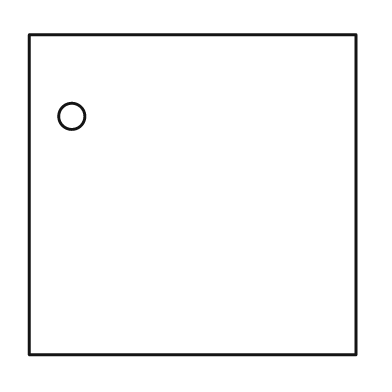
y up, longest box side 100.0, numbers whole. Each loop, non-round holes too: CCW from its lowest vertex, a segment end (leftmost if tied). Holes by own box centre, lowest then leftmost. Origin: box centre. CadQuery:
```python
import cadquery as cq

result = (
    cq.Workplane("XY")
    .moveTo(-50.0, -49.0)
    .lineTo(50.0, -49.0)
    .lineTo(50.0, 49.0)
    .lineTo(-50.0, 49.0)
    .close()
    .moveTo(-37.0, 24.0)
    .circle(4.0)
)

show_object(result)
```